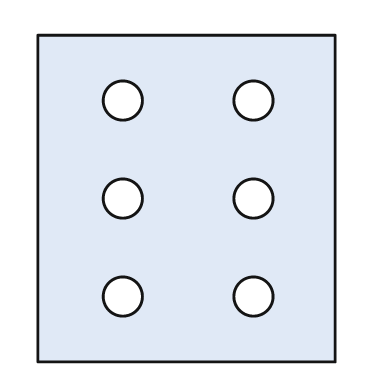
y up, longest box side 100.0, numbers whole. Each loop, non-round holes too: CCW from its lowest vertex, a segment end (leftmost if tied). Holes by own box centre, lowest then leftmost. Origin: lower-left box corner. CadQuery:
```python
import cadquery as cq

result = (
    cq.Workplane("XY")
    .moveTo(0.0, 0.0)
    .lineTo(91.0, 0.0)
    .lineTo(91.0, 100.0)
    .lineTo(0.0, 100.0)
    .close()
    .moveTo(26.0, 20.0)
    .circle(6.0)
    .moveTo(66.0, 20.0)
    .circle(6.0)
    .moveTo(26.0, 50.0)
    .circle(6.0)
    .moveTo(66.0, 50.0)
    .circle(6.0)
    .moveTo(26.0, 80.0)
    .circle(6.0)
    .moveTo(66.0, 80.0)
    .circle(6.0)
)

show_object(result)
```